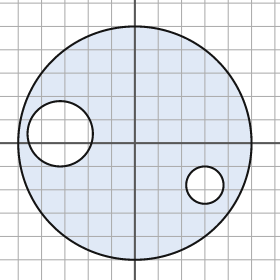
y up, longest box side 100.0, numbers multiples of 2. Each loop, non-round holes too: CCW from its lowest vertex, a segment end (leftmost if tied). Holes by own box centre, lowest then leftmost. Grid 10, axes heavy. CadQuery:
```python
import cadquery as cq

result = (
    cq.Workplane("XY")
    .moveTo(0.0, 0.0)
    .circle(50.0)
    .moveTo(30.0, -18.0)
    .circle(8.0)
    .moveTo(-32.0, 4.0)
    .circle(14.0)
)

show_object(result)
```